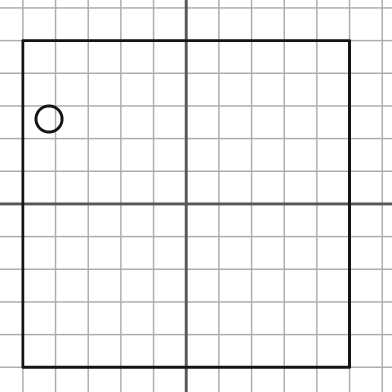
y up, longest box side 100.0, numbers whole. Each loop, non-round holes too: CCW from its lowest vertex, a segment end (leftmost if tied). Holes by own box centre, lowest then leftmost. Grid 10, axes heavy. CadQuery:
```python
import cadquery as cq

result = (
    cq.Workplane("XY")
    .moveTo(-50.0, -50.0)
    .lineTo(50.0, -50.0)
    .lineTo(50.0, 50.0)
    .lineTo(-50.0, 50.0)
    .close()
    .moveTo(-42.0, 26.0)
    .circle(4.0)
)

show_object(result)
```